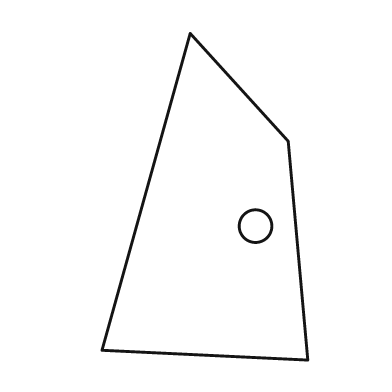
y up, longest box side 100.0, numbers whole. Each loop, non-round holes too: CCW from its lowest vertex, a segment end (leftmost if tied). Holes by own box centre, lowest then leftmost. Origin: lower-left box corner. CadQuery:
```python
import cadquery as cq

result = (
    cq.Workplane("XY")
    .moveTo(63.0, 0.0)
    .lineTo(57.0, 67.0)
    .lineTo(27.0, 100.0)
    .lineTo(0.0, 3.0)
    .close()
    .moveTo(47.0, 41.0)
    .circle(5.0)
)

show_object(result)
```